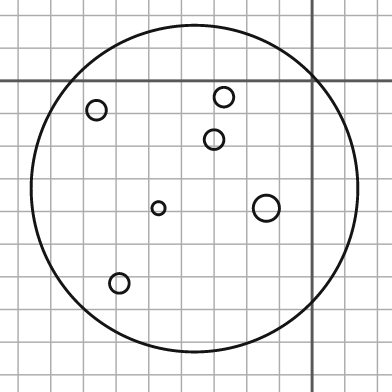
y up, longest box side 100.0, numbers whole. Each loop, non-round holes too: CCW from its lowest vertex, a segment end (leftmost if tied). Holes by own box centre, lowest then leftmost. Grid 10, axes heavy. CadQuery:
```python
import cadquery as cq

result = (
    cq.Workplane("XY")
    .moveTo(-36.0, -33.0)
    .circle(50.0)
    .moveTo(-59.0, -62.0)
    .circle(3.0)
    .moveTo(-47.0, -39.0)
    .circle(2.0)
    .moveTo(-14.0, -39.0)
    .circle(4.0)
    .moveTo(-30.0, -18.0)
    .circle(3.0)
    .moveTo(-66.0, -9.0)
    .circle(3.0)
    .moveTo(-27.0, -5.0)
    .circle(3.0)
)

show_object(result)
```